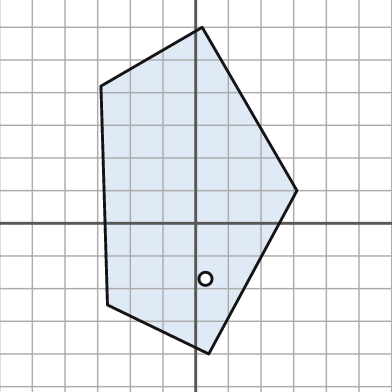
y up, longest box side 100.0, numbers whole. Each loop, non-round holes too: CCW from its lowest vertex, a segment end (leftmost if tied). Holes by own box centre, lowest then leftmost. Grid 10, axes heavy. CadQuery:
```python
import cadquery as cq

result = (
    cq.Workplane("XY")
    .moveTo(4.0, -40.0)
    .lineTo(31.0, 10.0)
    .lineTo(2.0, 60.0)
    .lineTo(-29.0, 42.0)
    .lineTo(-27.0, -25.0)
    .close()
    .moveTo(3.0, -17.0)
    .circle(2.0)
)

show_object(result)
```